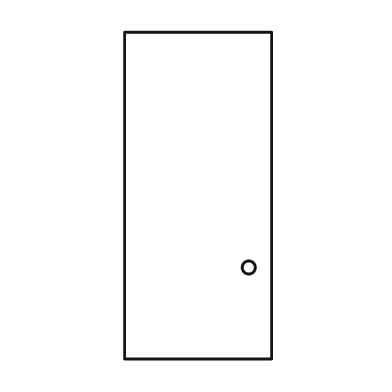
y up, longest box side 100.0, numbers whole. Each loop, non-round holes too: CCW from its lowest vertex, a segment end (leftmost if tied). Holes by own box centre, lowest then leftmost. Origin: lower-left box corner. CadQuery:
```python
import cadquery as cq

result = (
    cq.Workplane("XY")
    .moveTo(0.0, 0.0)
    .lineTo(45.0, 0.0)
    .lineTo(45.0, 100.0)
    .lineTo(0.0, 100.0)
    .close()
    .moveTo(38.0, 28.0)
    .circle(2.0)
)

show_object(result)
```